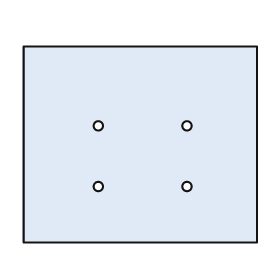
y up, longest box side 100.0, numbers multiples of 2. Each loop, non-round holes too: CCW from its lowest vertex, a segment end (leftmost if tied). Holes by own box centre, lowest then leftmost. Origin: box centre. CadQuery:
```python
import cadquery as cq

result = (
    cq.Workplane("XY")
    .moveTo(-50.0, -42.0)
    .lineTo(50.0, -42.0)
    .lineTo(50.0, 42.0)
    .lineTo(-50.0, 42.0)
    .close()
    .moveTo(-18.0, -18.0)
    .circle(2.0)
    .moveTo(20.0, -18.0)
    .circle(2.0)
    .moveTo(-18.0, 8.0)
    .circle(2.0)
    .moveTo(20.0, 8.0)
    .circle(2.0)
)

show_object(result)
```